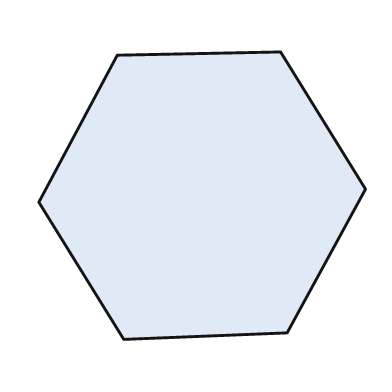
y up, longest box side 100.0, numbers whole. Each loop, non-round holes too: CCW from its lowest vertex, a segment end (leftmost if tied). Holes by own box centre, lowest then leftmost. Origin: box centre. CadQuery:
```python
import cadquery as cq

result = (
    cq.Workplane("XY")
    .moveTo(-24.0, -44.0)
    .lineTo(26.0, -42.0)
    .lineTo(50.0, 2.0)
    .lineTo(24.0, 44.0)
    .lineTo(-26.0, 43.0)
    .lineTo(-50.0, -2.0)
    .close()
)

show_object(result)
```